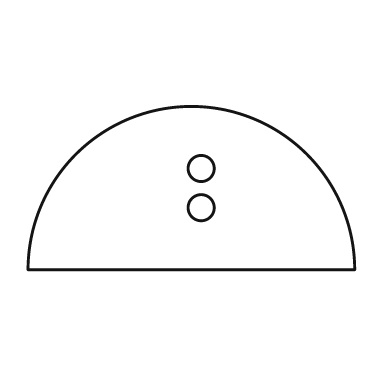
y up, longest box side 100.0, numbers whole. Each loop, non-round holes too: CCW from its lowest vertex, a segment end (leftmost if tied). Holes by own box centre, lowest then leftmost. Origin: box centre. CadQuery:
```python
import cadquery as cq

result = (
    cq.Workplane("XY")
    .moveTo(-50.0, -25.0)
    .lineTo(50.0, -25.0)
    .threePointArc((0.0, 25.0), (-50.0, -25.0))
    .close()
    .moveTo(3.0, -6.0)
    .circle(4.0)
    .moveTo(3.0, 6.0)
    .circle(4.0)
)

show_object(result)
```